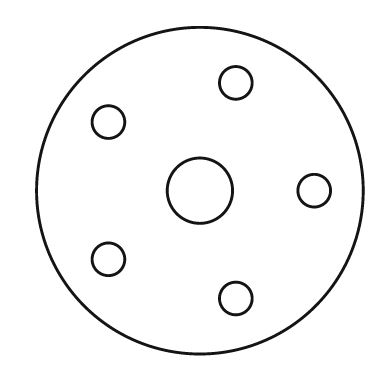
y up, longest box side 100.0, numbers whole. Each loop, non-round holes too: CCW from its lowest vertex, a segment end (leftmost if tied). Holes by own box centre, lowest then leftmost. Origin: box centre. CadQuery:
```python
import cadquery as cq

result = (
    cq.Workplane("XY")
    .moveTo(0.0, 0.0)
    .circle(50.0)
    .moveTo(11.0, -33.0)
    .circle(5.0)
    .moveTo(-28.0, -21.0)
    .circle(5.0)
    .moveTo(0.0, 0.0)
    .circle(10.0)
    .moveTo(35.0, 0.0)
    .circle(5.0)
    .moveTo(-28.0, 21.0)
    .circle(5.0)
    .moveTo(11.0, 33.0)
    .circle(5.0)
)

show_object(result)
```